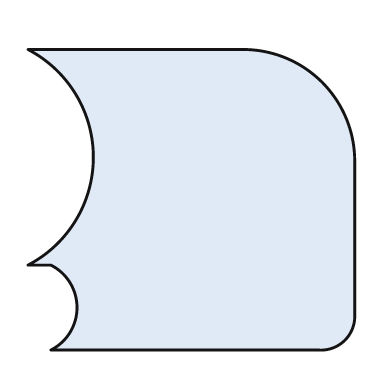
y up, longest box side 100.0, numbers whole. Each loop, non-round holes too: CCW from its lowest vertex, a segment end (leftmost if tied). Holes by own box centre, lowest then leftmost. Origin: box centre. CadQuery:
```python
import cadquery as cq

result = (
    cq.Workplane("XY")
    .moveTo(-43.0, -46.0)
    .lineTo(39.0, -46.0)
    .threePointArc((47.0, -43.0), (50.0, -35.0))
    .lineTo(50.0, 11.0)
    .threePointArc((40.0, 36.0), (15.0, 46.0))
    .lineTo(-50.0, 46.0)
    .threePointArc((-30.0, 13.0), (-50.0, -20.0))
    .lineTo(-43.0, -20.0)
    .threePointArc((-35.0, -33.0), (-43.0, -46.0))
    .close()
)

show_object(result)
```